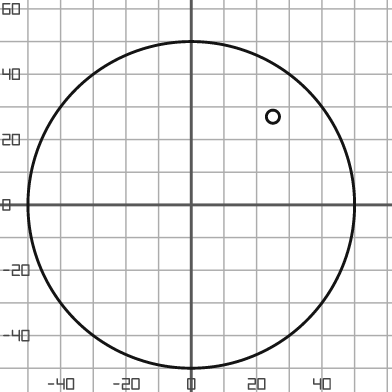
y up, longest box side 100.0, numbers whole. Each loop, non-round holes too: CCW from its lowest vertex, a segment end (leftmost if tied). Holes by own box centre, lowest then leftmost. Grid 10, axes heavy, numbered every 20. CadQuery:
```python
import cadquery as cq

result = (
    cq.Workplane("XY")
    .moveTo(0.0, 0.0)
    .circle(50.0)
    .moveTo(25.0, 27.0)
    .circle(2.0)
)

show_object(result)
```